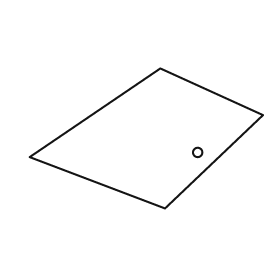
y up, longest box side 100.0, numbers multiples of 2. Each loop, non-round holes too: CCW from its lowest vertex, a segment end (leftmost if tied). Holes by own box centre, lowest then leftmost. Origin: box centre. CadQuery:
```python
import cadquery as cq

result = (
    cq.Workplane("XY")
    .moveTo(8.0, -30.0)
    .lineTo(50.0, 10.0)
    .lineTo(6.0, 30.0)
    .lineTo(-50.0, -8.0)
    .close()
    .moveTo(22.0, -6.0)
    .circle(2.0)
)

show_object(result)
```